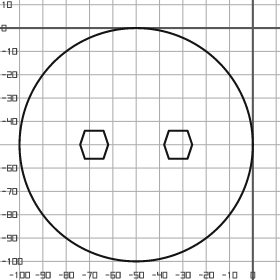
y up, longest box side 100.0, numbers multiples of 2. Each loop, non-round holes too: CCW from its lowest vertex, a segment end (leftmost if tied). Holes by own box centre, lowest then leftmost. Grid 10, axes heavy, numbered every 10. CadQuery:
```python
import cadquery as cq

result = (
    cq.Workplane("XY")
    .moveTo(-50.0, -50.0)
    .circle(50.0)
    .moveTo(-72.0, -56.0)
    .lineTo(-64.0, -56.0)
    .lineTo(-62.0, -50.0)
    .lineTo(-64.0, -44.0)
    .lineTo(-72.0, -44.0)
    .lineTo(-74.0, -50.0)
    .close()
    .moveTo(-36.0, -56.0)
    .lineTo(-28.0, -56.0)
    .lineTo(-26.0, -50.0)
    .lineTo(-28.0, -44.0)
    .lineTo(-36.0, -44.0)
    .lineTo(-38.0, -50.0)
    .close()
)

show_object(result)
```